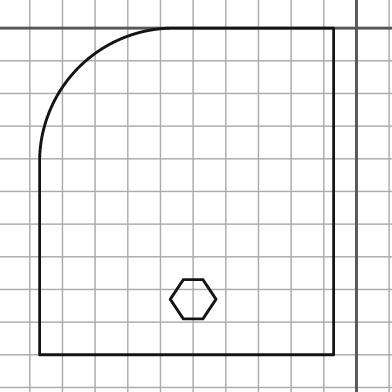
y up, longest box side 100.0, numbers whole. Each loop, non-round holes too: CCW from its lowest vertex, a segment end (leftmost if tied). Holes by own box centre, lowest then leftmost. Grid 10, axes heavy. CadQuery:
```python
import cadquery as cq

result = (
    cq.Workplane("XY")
    .moveTo(-97.0, -100.0)
    .lineTo(-7.0, -100.0)
    .lineTo(-7.0, 0.0)
    .lineTo(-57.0, 0.0)
    .threePointArc((-85.0, -12.0), (-97.0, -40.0))
    .close()
    .moveTo(-53.0, -89.0)
    .lineTo(-47.0, -89.0)
    .lineTo(-43.0, -83.0)
    .lineTo(-47.0, -77.0)
    .lineTo(-53.0, -77.0)
    .lineTo(-57.0, -83.0)
    .close()
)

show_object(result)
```